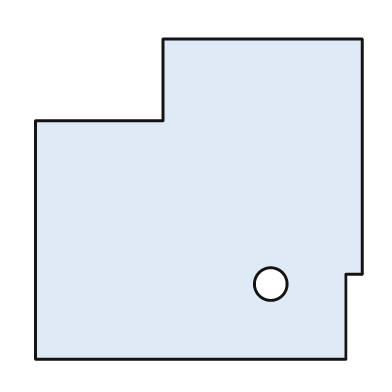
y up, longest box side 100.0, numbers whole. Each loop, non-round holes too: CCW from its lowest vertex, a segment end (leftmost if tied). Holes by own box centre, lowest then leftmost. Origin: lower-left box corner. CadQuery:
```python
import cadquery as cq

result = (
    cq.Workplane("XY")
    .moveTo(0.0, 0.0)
    .lineTo(95.0, 0.0)
    .lineTo(95.0, 26.0)
    .lineTo(100.0, 26.0)
    .lineTo(100.0, 98.0)
    .lineTo(39.0, 98.0)
    .lineTo(39.0, 73.0)
    .lineTo(0.0, 73.0)
    .close()
    .moveTo(72.0, 23.0)
    .circle(5.0)
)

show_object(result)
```